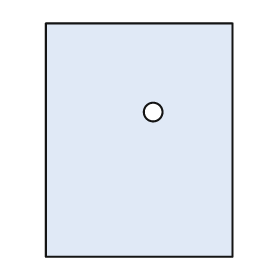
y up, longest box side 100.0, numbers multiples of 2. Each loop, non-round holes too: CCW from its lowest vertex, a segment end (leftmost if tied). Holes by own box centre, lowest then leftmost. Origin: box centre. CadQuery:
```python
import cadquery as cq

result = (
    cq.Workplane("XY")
    .moveTo(-40.0, -50.0)
    .lineTo(40.0, -50.0)
    .lineTo(40.0, 50.0)
    .lineTo(-40.0, 50.0)
    .close()
    .moveTo(6.0, 12.0)
    .circle(4.0)
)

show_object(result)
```